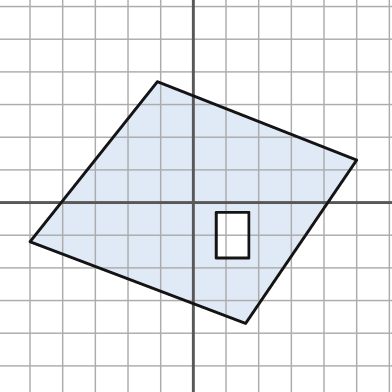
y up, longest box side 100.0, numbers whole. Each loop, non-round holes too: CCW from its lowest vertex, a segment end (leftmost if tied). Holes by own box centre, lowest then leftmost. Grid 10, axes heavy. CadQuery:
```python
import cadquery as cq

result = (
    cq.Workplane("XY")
    .moveTo(16.0, -37.0)
    .lineTo(50.0, 13.0)
    .lineTo(-11.0, 37.0)
    .lineTo(-50.0, -12.0)
    .close()
    .moveTo(7.0, -17.0)
    .lineTo(17.0, -17.0)
    .lineTo(17.0, -3.0)
    .lineTo(7.0, -3.0)
    .close()
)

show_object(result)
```